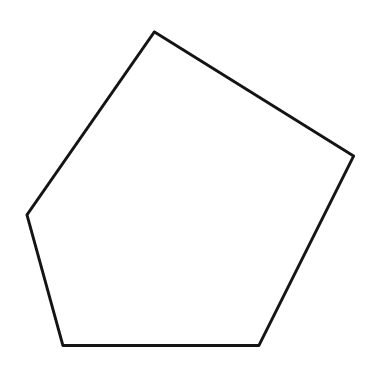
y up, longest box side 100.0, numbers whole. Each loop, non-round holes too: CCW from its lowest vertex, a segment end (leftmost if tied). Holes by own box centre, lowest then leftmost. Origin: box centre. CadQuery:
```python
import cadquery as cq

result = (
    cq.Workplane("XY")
    .moveTo(-39.0, -48.0)
    .lineTo(21.0, -48.0)
    .lineTo(50.0, 10.0)
    .lineTo(-11.0, 48.0)
    .lineTo(-50.0, -8.0)
    .close()
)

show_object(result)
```